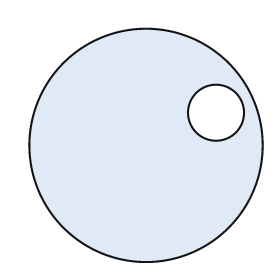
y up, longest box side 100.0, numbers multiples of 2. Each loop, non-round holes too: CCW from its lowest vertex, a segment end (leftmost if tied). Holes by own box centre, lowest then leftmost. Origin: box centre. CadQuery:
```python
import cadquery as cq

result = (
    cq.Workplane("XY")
    .moveTo(0.0, 0.0)
    .circle(50.0)
    .moveTo(30.0, 14.0)
    .circle(12.0)
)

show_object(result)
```